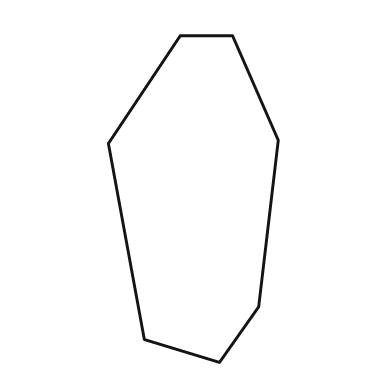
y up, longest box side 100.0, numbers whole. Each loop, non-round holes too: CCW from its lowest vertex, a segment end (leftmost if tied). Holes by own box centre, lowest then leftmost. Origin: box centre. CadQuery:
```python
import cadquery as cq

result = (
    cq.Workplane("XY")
    .moveTo(8.0, -50.0)
    .lineTo(20.0, -33.0)
    .lineTo(26.0, 18.0)
    .lineTo(12.0, 50.0)
    .lineTo(-4.0, 50.0)
    .lineTo(-26.0, 17.0)
    .lineTo(-15.0, -43.0)
    .close()
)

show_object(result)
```